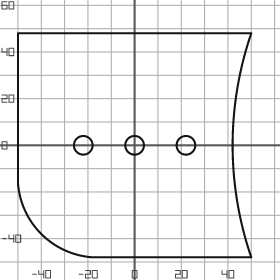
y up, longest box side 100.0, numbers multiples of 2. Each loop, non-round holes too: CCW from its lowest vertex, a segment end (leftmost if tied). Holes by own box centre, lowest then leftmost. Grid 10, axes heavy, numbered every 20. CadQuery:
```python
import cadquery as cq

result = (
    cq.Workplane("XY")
    .moveTo(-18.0, -48.0)
    .lineTo(50.0, -48.0)
    .threePointArc((42.0, 0.0), (50.0, 48.0))
    .lineTo(-50.0, 48.0)
    .lineTo(-50.0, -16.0)
    .threePointArc((-40.0, -38.0), (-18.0, -48.0))
    .close()
    .moveTo(-22.0, 0.0)
    .circle(4.0)
    .moveTo(0.0, 0.0)
    .circle(4.0)
    .moveTo(22.0, 0.0)
    .circle(4.0)
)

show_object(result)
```